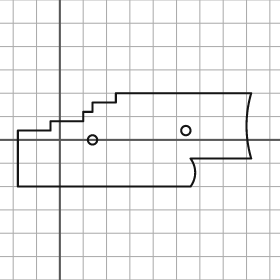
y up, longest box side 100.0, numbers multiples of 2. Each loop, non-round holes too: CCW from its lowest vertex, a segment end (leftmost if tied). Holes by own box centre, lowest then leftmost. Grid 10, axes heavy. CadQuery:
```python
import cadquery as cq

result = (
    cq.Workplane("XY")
    .moveTo(-18.0, -20.0)
    .lineTo(56.0, -20.0)
    .threePointArc((58.0, -14.0), (56.0, -8.0))
    .lineTo(82.0, -8.0)
    .threePointArc((80.0, 6.0), (82.0, 20.0))
    .lineTo(24.0, 20.0)
    .lineTo(24.0, 16.0)
    .lineTo(14.0, 16.0)
    .lineTo(14.0, 12.0)
    .lineTo(10.0, 12.0)
    .lineTo(10.0, 8.0)
    .lineTo(-4.0, 8.0)
    .lineTo(-4.0, 4.0)
    .lineTo(-18.0, 4.0)
    .close()
    .moveTo(14.0, 0.0)
    .circle(2.0)
    .moveTo(54.0, 4.0)
    .circle(2.0)
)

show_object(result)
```